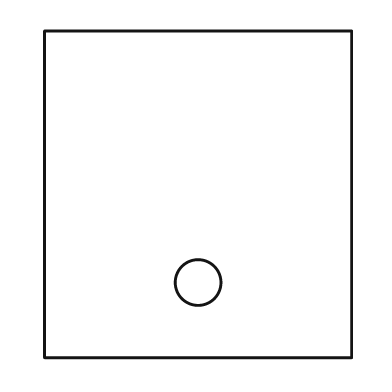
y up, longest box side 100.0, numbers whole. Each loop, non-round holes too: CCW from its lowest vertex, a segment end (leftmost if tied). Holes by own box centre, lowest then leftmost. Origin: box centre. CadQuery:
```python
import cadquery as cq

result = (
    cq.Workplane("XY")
    .moveTo(-47.0, -50.0)
    .lineTo(47.0, -50.0)
    .lineTo(47.0, 50.0)
    .lineTo(-47.0, 50.0)
    .close()
    .moveTo(0.0, -27.0)
    .circle(7.0)
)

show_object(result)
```